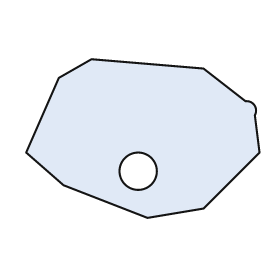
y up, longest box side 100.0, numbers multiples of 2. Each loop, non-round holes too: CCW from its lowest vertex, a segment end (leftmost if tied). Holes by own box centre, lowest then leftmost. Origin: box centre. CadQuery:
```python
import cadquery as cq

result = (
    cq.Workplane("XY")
    .moveTo(2.0, -34.0)
    .lineTo(26.0, -30.0)
    .lineTo(50.0, -6.0)
    .lineTo(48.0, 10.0)
    .threePointArc((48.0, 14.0), (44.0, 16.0))
    .lineTo(26.0, 30.0)
    .lineTo(-22.0, 34.0)
    .lineTo(-36.0, 26.0)
    .lineTo(-50.0, -6.0)
    .lineTo(-34.0, -20.0)
    .close()
    .moveTo(-2.0, -14.0)
    .circle(8.0)
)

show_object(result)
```